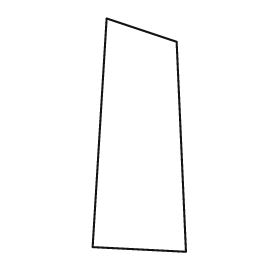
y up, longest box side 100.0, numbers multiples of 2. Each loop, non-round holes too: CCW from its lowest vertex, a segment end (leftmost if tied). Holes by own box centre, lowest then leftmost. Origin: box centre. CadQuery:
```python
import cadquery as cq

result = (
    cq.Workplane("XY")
    .moveTo(20.0, -50.0)
    .lineTo(16.0, 40.0)
    .lineTo(-14.0, 50.0)
    .lineTo(-20.0, -48.0)
    .close()
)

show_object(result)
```